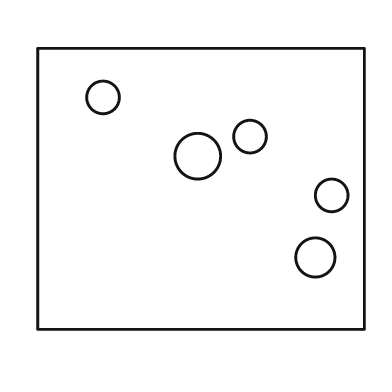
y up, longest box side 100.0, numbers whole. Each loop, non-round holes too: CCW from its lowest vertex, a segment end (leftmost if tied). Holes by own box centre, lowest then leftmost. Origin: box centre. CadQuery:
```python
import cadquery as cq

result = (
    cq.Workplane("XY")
    .moveTo(-50.0, -43.0)
    .lineTo(50.0, -43.0)
    .lineTo(50.0, 43.0)
    .lineTo(-50.0, 43.0)
    .close()
    .moveTo(35.0, -21.0)
    .circle(6.0)
    .moveTo(40.0, -2.0)
    .circle(5.0)
    .moveTo(-1.0, 10.0)
    .circle(7.0)
    .moveTo(15.0, 16.0)
    .circle(5.0)
    .moveTo(-30.0, 28.0)
    .circle(5.0)
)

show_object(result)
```